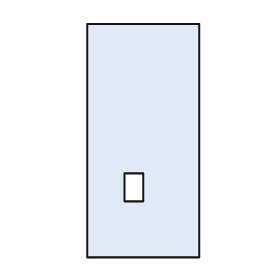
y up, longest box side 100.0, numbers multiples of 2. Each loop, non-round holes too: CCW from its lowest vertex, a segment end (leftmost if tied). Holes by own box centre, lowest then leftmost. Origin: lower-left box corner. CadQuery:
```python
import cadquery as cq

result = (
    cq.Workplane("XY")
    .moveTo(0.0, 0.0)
    .lineTo(48.0, 0.0)
    .lineTo(48.0, 100.0)
    .lineTo(0.0, 100.0)
    .close()
    .moveTo(16.0, 24.0)
    .lineTo(24.0, 24.0)
    .lineTo(24.0, 36.0)
    .lineTo(16.0, 36.0)
    .close()
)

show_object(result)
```